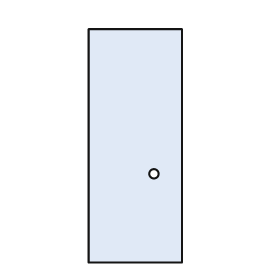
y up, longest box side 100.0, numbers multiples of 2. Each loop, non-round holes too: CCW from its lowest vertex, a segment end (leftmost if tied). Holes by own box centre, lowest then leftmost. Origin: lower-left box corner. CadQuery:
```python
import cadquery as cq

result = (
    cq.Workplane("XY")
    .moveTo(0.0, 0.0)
    .lineTo(40.0, 0.0)
    .lineTo(40.0, 100.0)
    .lineTo(0.0, 100.0)
    .close()
    .moveTo(28.0, 38.0)
    .circle(2.0)
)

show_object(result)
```